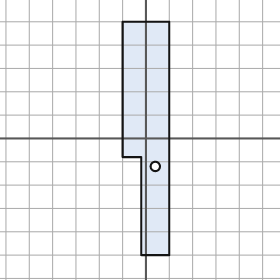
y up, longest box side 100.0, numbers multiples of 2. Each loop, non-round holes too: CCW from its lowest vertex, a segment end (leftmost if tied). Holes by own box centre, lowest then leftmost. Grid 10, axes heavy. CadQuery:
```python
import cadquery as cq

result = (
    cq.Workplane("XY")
    .moveTo(-2.0, -50.0)
    .lineTo(10.0, -50.0)
    .lineTo(10.0, 50.0)
    .lineTo(-10.0, 50.0)
    .lineTo(-10.0, -8.0)
    .lineTo(-2.0, -8.0)
    .close()
    .moveTo(4.0, -12.0)
    .circle(2.0)
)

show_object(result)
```